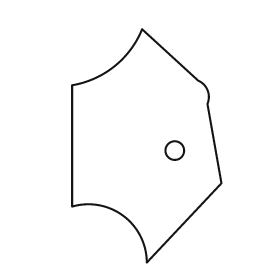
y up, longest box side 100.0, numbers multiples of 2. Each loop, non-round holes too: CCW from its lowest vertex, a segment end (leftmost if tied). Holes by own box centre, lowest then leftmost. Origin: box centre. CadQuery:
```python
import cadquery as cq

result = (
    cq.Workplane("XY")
    .moveTo(0.0, -50.0)
    .lineTo(32.0, -16.0)
    .lineTo(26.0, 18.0)
    .threePointArc((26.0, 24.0), (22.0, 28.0))
    .lineTo(-2.0, 50.0)
    .threePointArc((-14.0, 34.0), (-32.0, 26.0))
    .lineTo(-32.0, -26.0)
    .threePointArc((-10.0, -30.0), (0.0, -50.0))
    .close()
    .moveTo(12.0, -2.0)
    .circle(4.0)
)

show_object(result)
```